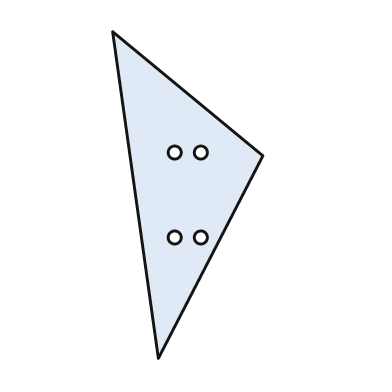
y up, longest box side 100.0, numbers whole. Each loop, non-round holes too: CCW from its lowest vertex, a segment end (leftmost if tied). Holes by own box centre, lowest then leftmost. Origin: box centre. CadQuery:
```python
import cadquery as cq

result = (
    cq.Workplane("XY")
    .moveTo(-9.0, -50.0)
    .lineTo(23.0, 12.0)
    .lineTo(-23.0, 50.0)
    .close()
    .moveTo(-4.0, -13.0)
    .circle(2.0)
    .moveTo(4.0, -13.0)
    .circle(2.0)
    .moveTo(-4.0, 13.0)
    .circle(2.0)
    .moveTo(4.0, 13.0)
    .circle(2.0)
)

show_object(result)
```